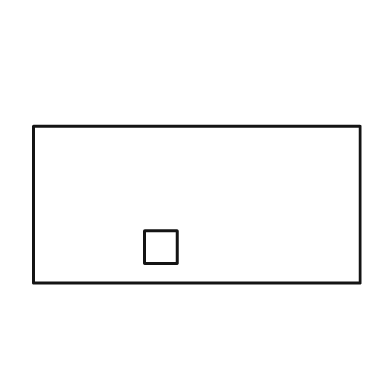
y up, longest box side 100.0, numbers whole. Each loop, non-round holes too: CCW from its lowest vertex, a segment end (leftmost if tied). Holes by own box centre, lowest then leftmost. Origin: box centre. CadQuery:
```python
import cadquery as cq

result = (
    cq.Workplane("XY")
    .moveTo(-50.0, -24.0)
    .lineTo(50.0, -24.0)
    .lineTo(50.0, 24.0)
    .lineTo(-50.0, 24.0)
    .close()
    .moveTo(-16.0, -18.0)
    .lineTo(-6.0, -18.0)
    .lineTo(-6.0, -8.0)
    .lineTo(-16.0, -8.0)
    .close()
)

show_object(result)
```